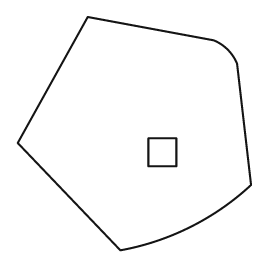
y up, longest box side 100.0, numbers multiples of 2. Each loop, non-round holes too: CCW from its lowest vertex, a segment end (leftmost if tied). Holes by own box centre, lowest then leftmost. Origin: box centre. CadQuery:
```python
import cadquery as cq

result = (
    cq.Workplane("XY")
    .moveTo(-6.0, -50.0)
    .threePointArc((24.0, -40.0), (50.0, -22.0))
    .lineTo(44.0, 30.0)
    .threePointArc((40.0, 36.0), (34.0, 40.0))
    .lineTo(-20.0, 50.0)
    .lineTo(-50.0, -4.0)
    .close()
    .moveTo(6.0, -14.0)
    .lineTo(18.0, -14.0)
    .lineTo(18.0, -2.0)
    .lineTo(6.0, -2.0)
    .close()
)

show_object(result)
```